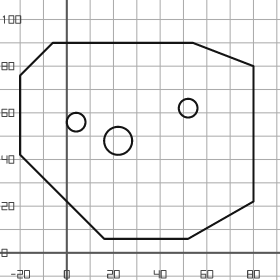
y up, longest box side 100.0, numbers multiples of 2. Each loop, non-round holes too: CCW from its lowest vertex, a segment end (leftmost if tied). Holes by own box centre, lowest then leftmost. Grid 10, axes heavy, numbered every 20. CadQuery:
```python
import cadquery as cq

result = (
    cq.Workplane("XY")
    .moveTo(16.0, 6.0)
    .lineTo(52.0, 6.0)
    .lineTo(80.0, 22.0)
    .lineTo(80.0, 80.0)
    .lineTo(54.0, 90.0)
    .lineTo(-6.0, 90.0)
    .lineTo(-20.0, 76.0)
    .lineTo(-20.0, 42.0)
    .close()
    .moveTo(22.0, 48.0)
    .circle(6.0)
    .moveTo(4.0, 56.0)
    .circle(4.0)
    .moveTo(52.0, 62.0)
    .circle(4.0)
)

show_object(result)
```